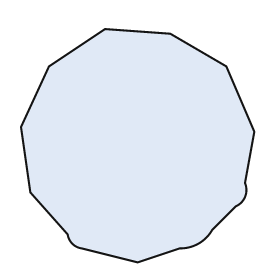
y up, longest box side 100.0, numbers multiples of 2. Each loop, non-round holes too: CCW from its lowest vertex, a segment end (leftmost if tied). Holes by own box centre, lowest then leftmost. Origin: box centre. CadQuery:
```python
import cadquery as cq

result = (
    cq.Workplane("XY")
    .moveTo(0.0, -50.0)
    .lineTo(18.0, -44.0)
    .threePointArc((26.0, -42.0), (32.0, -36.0))
    .lineTo(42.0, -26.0)
    .threePointArc((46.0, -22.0), (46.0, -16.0))
    .lineTo(50.0, 6.0)
    .lineTo(38.0, 34.0)
    .lineTo(14.0, 48.0)
    .lineTo(-14.0, 50.0)
    .lineTo(-38.0, 34.0)
    .lineTo(-50.0, 8.0)
    .lineTo(-46.0, -20.0)
    .lineTo(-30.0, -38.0)
    .threePointArc((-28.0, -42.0), (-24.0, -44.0))
    .close()
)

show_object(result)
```